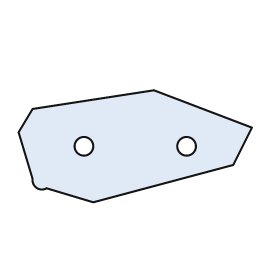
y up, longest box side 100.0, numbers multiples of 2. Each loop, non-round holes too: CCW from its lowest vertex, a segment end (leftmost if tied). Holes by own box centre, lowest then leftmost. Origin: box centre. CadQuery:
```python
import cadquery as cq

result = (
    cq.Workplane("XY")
    .moveTo(-18.0, -24.0)
    .lineTo(42.0, -8.0)
    .lineTo(50.0, 8.0)
    .lineTo(8.0, 24.0)
    .lineTo(-44.0, 16.0)
    .lineTo(-50.0, 6.0)
    .lineTo(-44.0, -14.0)
    .threePointArc((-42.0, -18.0), (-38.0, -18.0))
    .close()
    .moveTo(-22.0, 0.0)
    .circle(4.0)
    .moveTo(22.0, 0.0)
    .circle(4.0)
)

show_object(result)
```